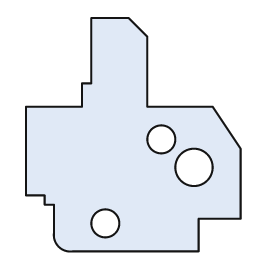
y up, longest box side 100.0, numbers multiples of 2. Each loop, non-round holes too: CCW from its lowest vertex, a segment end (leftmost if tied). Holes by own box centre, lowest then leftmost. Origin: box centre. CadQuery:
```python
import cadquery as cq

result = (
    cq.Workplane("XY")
    .moveTo(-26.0, -50.0)
    .lineTo(28.0, -50.0)
    .lineTo(28.0, -36.0)
    .lineTo(46.0, -36.0)
    .lineTo(46.0, -6.0)
    .lineTo(34.0, 12.0)
    .lineTo(6.0, 12.0)
    .lineTo(6.0, 42.0)
    .lineTo(-2.0, 50.0)
    .lineTo(-18.0, 50.0)
    .lineTo(-18.0, 22.0)
    .lineTo(-22.0, 22.0)
    .lineTo(-22.0, 12.0)
    .lineTo(-46.0, 12.0)
    .lineTo(-46.0, -26.0)
    .lineTo(-38.0, -26.0)
    .lineTo(-38.0, -30.0)
    .lineTo(-34.0, -30.0)
    .lineTo(-34.0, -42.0)
    .threePointArc((-32.0, -48.0), (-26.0, -50.0))
    .close()
    .moveTo(-12.0, -38.0)
    .circle(6.0)
    .moveTo(26.0, -14.0)
    .circle(8.0)
    .moveTo(12.0, -2.0)
    .circle(6.0)
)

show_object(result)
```